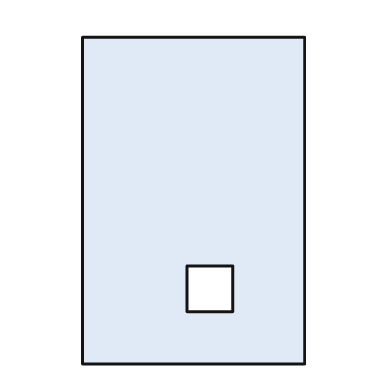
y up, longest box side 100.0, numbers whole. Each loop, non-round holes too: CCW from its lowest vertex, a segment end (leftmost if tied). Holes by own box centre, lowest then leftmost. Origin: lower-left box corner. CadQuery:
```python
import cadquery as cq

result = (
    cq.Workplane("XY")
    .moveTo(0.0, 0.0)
    .lineTo(68.0, 0.0)
    .lineTo(68.0, 100.0)
    .lineTo(0.0, 100.0)
    .close()
    .moveTo(32.0, 16.0)
    .lineTo(46.0, 16.0)
    .lineTo(46.0, 30.0)
    .lineTo(32.0, 30.0)
    .close()
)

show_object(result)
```